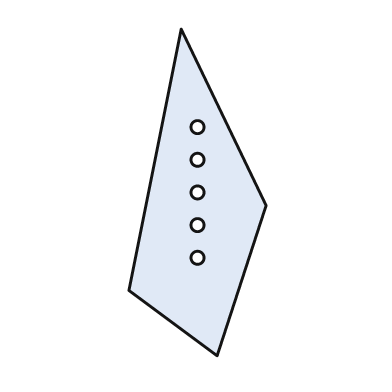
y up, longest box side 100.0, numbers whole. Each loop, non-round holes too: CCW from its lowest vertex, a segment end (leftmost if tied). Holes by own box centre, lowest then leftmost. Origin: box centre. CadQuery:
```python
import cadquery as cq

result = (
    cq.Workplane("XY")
    .moveTo(6.0, -50.0)
    .lineTo(21.0, -4.0)
    .lineTo(-5.0, 50.0)
    .lineTo(-21.0, -30.0)
    .close()
    .moveTo(0.0, -20.0)
    .circle(2.0)
    .moveTo(0.0, -10.0)
    .circle(2.0)
    .moveTo(0.0, 0.0)
    .circle(2.0)
    .moveTo(0.0, 10.0)
    .circle(2.0)
    .moveTo(0.0, 20.0)
    .circle(2.0)
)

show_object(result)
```